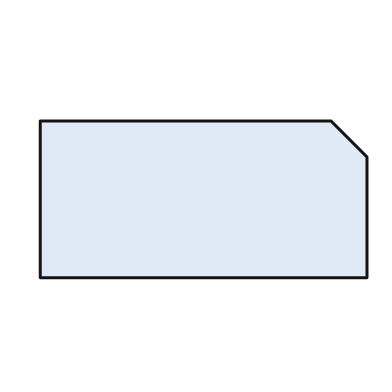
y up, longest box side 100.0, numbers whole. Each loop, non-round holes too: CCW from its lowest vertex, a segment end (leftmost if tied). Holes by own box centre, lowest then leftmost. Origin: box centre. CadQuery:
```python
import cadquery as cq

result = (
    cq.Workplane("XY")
    .moveTo(-50.0, -24.0)
    .lineTo(50.0, -24.0)
    .lineTo(50.0, 13.0)
    .lineTo(39.0, 24.0)
    .lineTo(-50.0, 24.0)
    .close()
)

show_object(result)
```